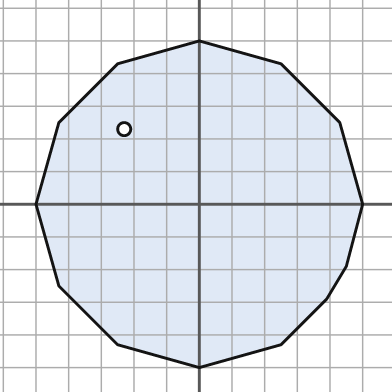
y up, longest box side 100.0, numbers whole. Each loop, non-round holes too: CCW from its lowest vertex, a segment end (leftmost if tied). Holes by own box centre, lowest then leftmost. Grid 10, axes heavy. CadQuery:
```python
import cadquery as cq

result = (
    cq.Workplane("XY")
    .moveTo(0.0, -50.0)
    .lineTo(25.0, -43.0)
    .lineTo(39.0, -29.0)
    .lineTo(45.0, -19.0)
    .lineTo(50.0, 0.0)
    .lineTo(43.0, 25.0)
    .lineTo(25.0, 43.0)
    .lineTo(0.0, 50.0)
    .lineTo(-25.0, 43.0)
    .lineTo(-43.0, 25.0)
    .lineTo(-50.0, 0.0)
    .lineTo(-43.0, -25.0)
    .lineTo(-25.0, -43.0)
    .close()
    .moveTo(-23.0, 23.0)
    .circle(2.0)
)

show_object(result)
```